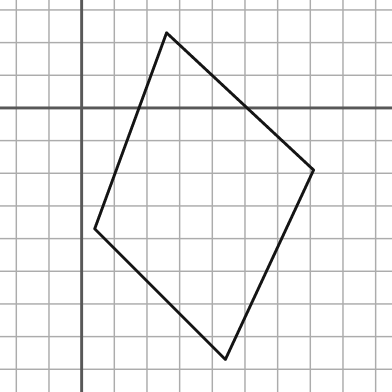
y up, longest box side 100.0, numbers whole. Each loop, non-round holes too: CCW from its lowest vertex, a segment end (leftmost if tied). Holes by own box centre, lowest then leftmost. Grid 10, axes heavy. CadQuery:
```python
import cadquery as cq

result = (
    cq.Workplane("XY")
    .moveTo(44.0, -77.0)
    .lineTo(71.0, -19.0)
    .lineTo(26.0, 23.0)
    .lineTo(4.0, -37.0)
    .close()
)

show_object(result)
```